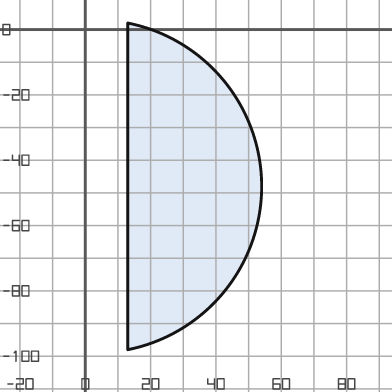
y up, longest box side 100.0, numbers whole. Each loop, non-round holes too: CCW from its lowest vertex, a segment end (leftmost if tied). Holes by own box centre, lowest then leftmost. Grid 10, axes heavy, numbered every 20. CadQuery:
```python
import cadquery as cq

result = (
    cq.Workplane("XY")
    .moveTo(13.0, -98.0)
    .threePointArc((54.0, -48.0), (13.0, 2.0))
    .close()
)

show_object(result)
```